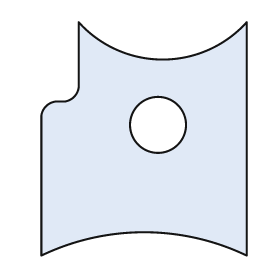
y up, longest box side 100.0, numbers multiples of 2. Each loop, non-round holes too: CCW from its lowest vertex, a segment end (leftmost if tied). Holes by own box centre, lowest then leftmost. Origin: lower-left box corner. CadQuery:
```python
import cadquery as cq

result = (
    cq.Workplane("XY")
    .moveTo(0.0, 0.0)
    .threePointArc((44.0, 10.0), (88.0, 0.0))
    .lineTo(88.0, 100.0)
    .threePointArc((52.0, 84.0), (16.0, 100.0))
    .lineTo(16.0, 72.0)
    .threePointArc((14.0, 68.0), (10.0, 66.0))
    .lineTo(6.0, 66.0)
    .threePointArc((2.0, 64.0), (0.0, 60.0))
    .close()
    .moveTo(50.0, 56.0)
    .circle(12.0)
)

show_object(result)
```